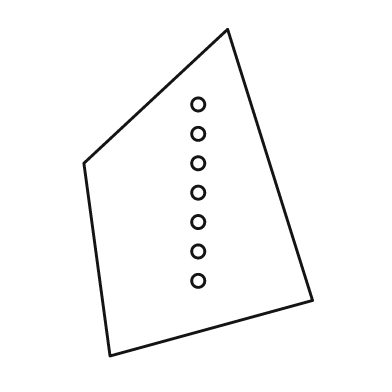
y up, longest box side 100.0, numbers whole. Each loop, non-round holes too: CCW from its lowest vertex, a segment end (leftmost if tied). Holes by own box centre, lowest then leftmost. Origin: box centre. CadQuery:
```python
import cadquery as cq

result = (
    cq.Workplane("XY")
    .moveTo(-27.0, -50.0)
    .lineTo(35.0, -33.0)
    .lineTo(9.0, 50.0)
    .lineTo(-35.0, 9.0)
    .close()
    .moveTo(0.0, -27.0)
    .circle(2.0)
    .moveTo(0.0, -18.0)
    .circle(2.0)
    .moveTo(0.0, -9.0)
    .circle(2.0)
    .moveTo(0.0, 0.0)
    .circle(2.0)
    .moveTo(0.0, 9.0)
    .circle(2.0)
    .moveTo(0.0, 18.0)
    .circle(2.0)
    .moveTo(0.0, 27.0)
    .circle(2.0)
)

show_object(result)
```